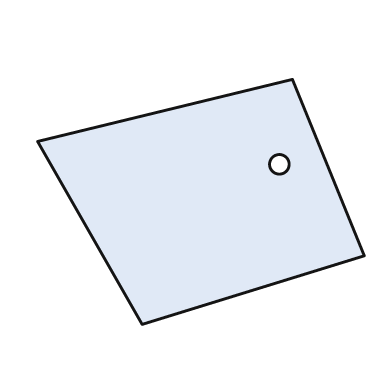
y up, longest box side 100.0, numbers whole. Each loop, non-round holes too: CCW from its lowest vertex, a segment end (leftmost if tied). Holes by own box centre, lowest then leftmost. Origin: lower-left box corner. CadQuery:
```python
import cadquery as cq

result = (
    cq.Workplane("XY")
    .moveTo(32.0, 0.0)
    .lineTo(100.0, 21.0)
    .lineTo(78.0, 75.0)
    .lineTo(0.0, 56.0)
    .close()
    .moveTo(74.0, 49.0)
    .circle(3.0)
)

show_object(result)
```